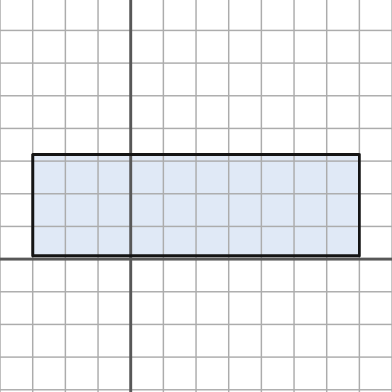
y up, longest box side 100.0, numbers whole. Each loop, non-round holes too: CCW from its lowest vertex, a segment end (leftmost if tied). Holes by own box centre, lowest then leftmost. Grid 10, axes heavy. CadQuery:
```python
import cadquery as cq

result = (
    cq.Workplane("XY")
    .moveTo(-30.0, 1.0)
    .lineTo(70.0, 1.0)
    .lineTo(70.0, 32.0)
    .lineTo(-30.0, 32.0)
    .close()
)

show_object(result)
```